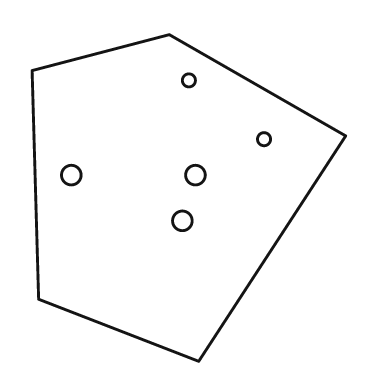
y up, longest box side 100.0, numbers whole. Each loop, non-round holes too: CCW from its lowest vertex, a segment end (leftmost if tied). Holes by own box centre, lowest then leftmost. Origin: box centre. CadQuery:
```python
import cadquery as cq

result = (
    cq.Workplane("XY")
    .moveTo(3.0, -50.0)
    .lineTo(48.0, 19.0)
    .lineTo(-6.0, 50.0)
    .lineTo(-48.0, 39.0)
    .lineTo(-46.0, -31.0)
    .close()
    .moveTo(-2.0, -7.0)
    .circle(3.0)
    .moveTo(-36.0, 7.0)
    .circle(3.0)
    .moveTo(2.0, 7.0)
    .circle(3.0)
    .moveTo(23.0, 18.0)
    .circle(2.0)
    .moveTo(0.0, 36.0)
    .circle(2.0)
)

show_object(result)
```